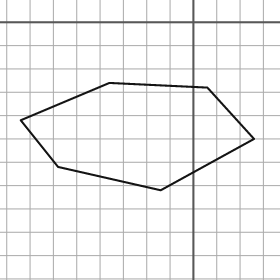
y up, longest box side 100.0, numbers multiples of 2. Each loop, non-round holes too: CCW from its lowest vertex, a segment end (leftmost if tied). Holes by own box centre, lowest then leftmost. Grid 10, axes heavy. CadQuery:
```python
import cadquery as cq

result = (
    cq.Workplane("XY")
    .moveTo(-14.0, -72.0)
    .lineTo(26.0, -50.0)
    .lineTo(6.0, -28.0)
    .lineTo(-36.0, -26.0)
    .lineTo(-74.0, -42.0)
    .lineTo(-58.0, -62.0)
    .close()
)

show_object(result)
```